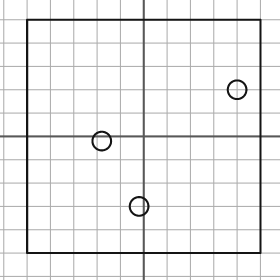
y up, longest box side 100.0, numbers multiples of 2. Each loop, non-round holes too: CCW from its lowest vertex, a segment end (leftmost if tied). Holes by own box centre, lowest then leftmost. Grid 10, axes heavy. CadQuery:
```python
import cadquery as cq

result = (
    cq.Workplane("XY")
    .moveTo(-50.0, -50.0)
    .lineTo(50.0, -50.0)
    .lineTo(50.0, 50.0)
    .lineTo(-50.0, 50.0)
    .close()
    .moveTo(-2.0, -30.0)
    .circle(4.0)
    .moveTo(-18.0, -2.0)
    .circle(4.0)
    .moveTo(40.0, 20.0)
    .circle(4.0)
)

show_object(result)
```